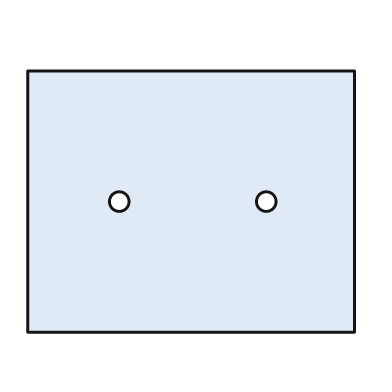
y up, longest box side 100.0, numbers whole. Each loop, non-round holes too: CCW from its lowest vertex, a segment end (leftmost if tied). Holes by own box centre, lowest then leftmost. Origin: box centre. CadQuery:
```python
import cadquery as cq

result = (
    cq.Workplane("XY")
    .moveTo(-50.0, -40.0)
    .lineTo(50.0, -40.0)
    .lineTo(50.0, 40.0)
    .lineTo(-50.0, 40.0)
    .close()
    .moveTo(-22.0, 0.0)
    .circle(3.0)
    .moveTo(23.0, 0.0)
    .circle(3.0)
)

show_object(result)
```